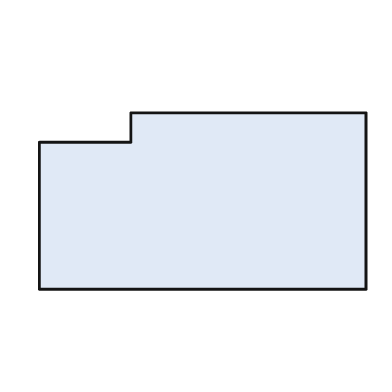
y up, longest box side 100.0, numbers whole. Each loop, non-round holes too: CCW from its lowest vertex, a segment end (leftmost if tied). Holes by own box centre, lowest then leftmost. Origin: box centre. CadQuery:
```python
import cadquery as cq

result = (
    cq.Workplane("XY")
    .moveTo(-50.0, -27.0)
    .lineTo(50.0, -27.0)
    .lineTo(50.0, 27.0)
    .lineTo(-22.0, 27.0)
    .lineTo(-22.0, 18.0)
    .lineTo(-50.0, 18.0)
    .close()
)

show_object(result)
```